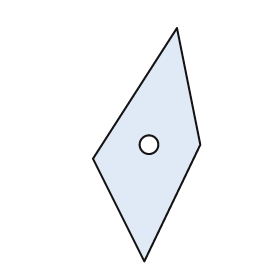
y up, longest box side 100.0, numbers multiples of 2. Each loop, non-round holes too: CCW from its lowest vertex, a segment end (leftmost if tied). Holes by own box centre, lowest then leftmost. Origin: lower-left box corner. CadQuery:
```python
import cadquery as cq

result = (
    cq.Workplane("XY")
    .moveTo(22.0, 0.0)
    .lineTo(46.0, 50.0)
    .lineTo(36.0, 100.0)
    .lineTo(0.0, 44.0)
    .close()
    .moveTo(24.0, 50.0)
    .circle(4.0)
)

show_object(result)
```